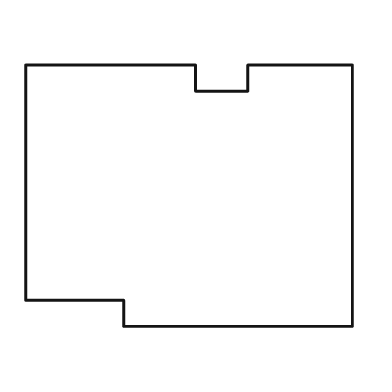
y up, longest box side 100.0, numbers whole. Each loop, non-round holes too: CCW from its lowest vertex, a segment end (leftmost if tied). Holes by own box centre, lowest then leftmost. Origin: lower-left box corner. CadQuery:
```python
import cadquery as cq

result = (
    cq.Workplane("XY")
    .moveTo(30.0, 0.0)
    .lineTo(100.0, 0.0)
    .lineTo(100.0, 80.0)
    .lineTo(68.0, 80.0)
    .lineTo(68.0, 72.0)
    .lineTo(52.0, 72.0)
    .lineTo(52.0, 80.0)
    .lineTo(0.0, 80.0)
    .lineTo(0.0, 8.0)
    .lineTo(30.0, 8.0)
    .close()
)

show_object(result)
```